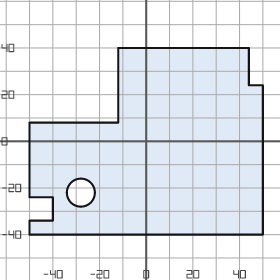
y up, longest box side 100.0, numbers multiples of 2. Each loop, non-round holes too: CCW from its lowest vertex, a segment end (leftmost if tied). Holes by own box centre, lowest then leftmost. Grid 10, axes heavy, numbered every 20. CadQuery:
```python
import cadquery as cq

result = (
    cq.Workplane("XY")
    .moveTo(-50.0, -40.0)
    .lineTo(50.0, -40.0)
    .lineTo(50.0, 24.0)
    .lineTo(44.0, 24.0)
    .lineTo(44.0, 40.0)
    .lineTo(-12.0, 40.0)
    .lineTo(-12.0, 8.0)
    .lineTo(-50.0, 8.0)
    .lineTo(-50.0, -24.0)
    .lineTo(-40.0, -24.0)
    .lineTo(-40.0, -34.0)
    .lineTo(-50.0, -34.0)
    .close()
    .moveTo(-28.0, -22.0)
    .circle(6.0)
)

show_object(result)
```